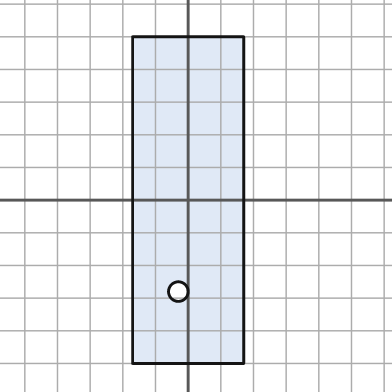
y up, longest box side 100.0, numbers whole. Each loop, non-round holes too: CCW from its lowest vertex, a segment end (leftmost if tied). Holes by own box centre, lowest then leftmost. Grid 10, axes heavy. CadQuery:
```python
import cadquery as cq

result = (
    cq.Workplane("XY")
    .moveTo(-17.0, -50.0)
    .lineTo(17.0, -50.0)
    .lineTo(17.0, 50.0)
    .lineTo(-17.0, 50.0)
    .close()
    .moveTo(-3.0, -28.0)
    .circle(3.0)
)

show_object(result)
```